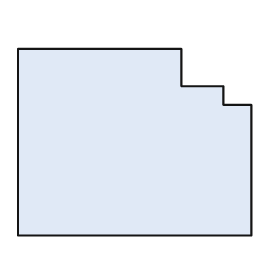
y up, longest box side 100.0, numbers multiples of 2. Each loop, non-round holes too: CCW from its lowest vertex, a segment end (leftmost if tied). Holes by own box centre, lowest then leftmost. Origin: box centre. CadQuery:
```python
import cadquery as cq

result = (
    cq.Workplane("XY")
    .moveTo(-50.0, -40.0)
    .lineTo(50.0, -40.0)
    .lineTo(50.0, 16.0)
    .lineTo(38.0, 16.0)
    .lineTo(38.0, 24.0)
    .lineTo(20.0, 24.0)
    .lineTo(20.0, 40.0)
    .lineTo(-50.0, 40.0)
    .close()
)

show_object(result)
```